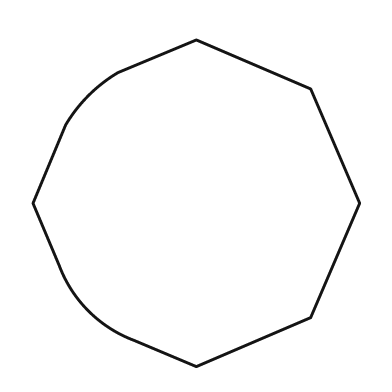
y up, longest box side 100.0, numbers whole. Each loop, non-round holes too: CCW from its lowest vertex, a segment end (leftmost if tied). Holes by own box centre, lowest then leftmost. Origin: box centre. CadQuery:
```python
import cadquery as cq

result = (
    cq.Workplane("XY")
    .moveTo(0.0, -50.0)
    .lineTo(35.0, -35.0)
    .lineTo(50.0, 0.0)
    .lineTo(35.0, 35.0)
    .lineTo(0.0, 50.0)
    .lineTo(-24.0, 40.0)
    .threePointArc((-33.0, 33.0), (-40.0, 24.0))
    .lineTo(-50.0, 0.0)
    .lineTo(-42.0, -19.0)
    .threePointArc((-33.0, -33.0), (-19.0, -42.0))
    .close()
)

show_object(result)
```